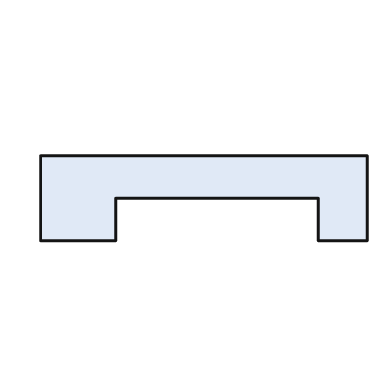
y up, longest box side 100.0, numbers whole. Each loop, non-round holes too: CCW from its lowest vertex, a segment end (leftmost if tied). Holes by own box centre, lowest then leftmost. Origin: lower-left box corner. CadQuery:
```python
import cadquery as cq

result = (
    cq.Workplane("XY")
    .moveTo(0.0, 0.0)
    .lineTo(23.0, 0.0)
    .lineTo(23.0, 13.0)
    .lineTo(85.0, 13.0)
    .lineTo(85.0, 0.0)
    .lineTo(100.0, 0.0)
    .lineTo(100.0, 26.0)
    .lineTo(0.0, 26.0)
    .close()
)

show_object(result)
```